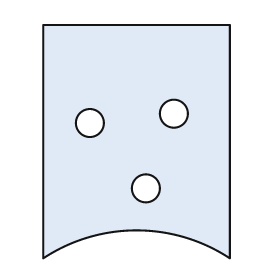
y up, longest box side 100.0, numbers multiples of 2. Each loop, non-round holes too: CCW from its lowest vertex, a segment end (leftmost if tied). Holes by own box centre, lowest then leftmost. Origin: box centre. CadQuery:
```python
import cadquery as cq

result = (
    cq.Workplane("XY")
    .moveTo(-40.0, -50.0)
    .threePointArc((0.0, -38.0), (40.0, -50.0))
    .lineTo(40.0, 50.0)
    .lineTo(-40.0, 50.0)
    .close()
    .moveTo(4.0, -20.0)
    .circle(6.0)
    .moveTo(-20.0, 8.0)
    .circle(6.0)
    .moveTo(16.0, 12.0)
    .circle(6.0)
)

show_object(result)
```